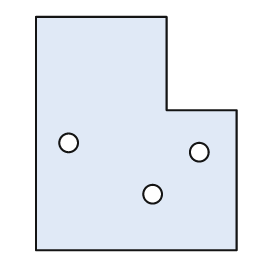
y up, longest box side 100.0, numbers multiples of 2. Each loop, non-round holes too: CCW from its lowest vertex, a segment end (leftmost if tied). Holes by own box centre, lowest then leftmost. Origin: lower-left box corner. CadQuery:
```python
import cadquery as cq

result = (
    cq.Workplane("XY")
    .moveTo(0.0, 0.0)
    .lineTo(86.0, 0.0)
    .lineTo(86.0, 60.0)
    .lineTo(56.0, 60.0)
    .lineTo(56.0, 100.0)
    .lineTo(0.0, 100.0)
    .close()
    .moveTo(50.0, 24.0)
    .circle(4.0)
    .moveTo(70.0, 42.0)
    .circle(4.0)
    .moveTo(14.0, 46.0)
    .circle(4.0)
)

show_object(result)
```